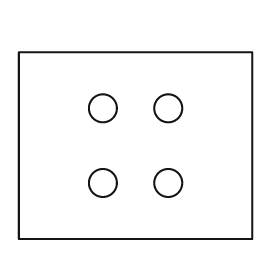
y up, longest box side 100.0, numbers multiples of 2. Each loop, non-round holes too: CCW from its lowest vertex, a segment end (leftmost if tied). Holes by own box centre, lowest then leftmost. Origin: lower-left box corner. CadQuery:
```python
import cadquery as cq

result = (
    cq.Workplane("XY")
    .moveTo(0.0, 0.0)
    .lineTo(100.0, 0.0)
    .lineTo(100.0, 80.0)
    .lineTo(0.0, 80.0)
    .close()
    .moveTo(36.0, 24.0)
    .circle(6.0)
    .moveTo(64.0, 24.0)
    .circle(6.0)
    .moveTo(36.0, 56.0)
    .circle(6.0)
    .moveTo(64.0, 56.0)
    .circle(6.0)
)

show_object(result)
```